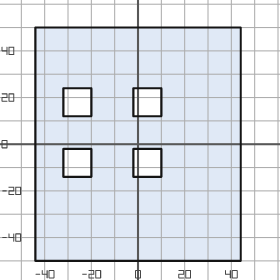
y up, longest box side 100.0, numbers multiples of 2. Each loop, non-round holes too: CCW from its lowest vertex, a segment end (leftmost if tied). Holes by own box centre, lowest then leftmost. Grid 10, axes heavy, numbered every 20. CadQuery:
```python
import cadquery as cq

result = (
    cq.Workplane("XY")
    .moveTo(-44.0, -50.0)
    .lineTo(44.0, -50.0)
    .lineTo(44.0, 50.0)
    .lineTo(-44.0, 50.0)
    .close()
    .moveTo(-32.0, -14.0)
    .lineTo(-20.0, -14.0)
    .lineTo(-20.0, -2.0)
    .lineTo(-32.0, -2.0)
    .close()
    .moveTo(-2.0, -14.0)
    .lineTo(10.0, -14.0)
    .lineTo(10.0, -2.0)
    .lineTo(-2.0, -2.0)
    .close()
    .moveTo(-32.0, 12.0)
    .lineTo(-20.0, 12.0)
    .lineTo(-20.0, 24.0)
    .lineTo(-32.0, 24.0)
    .close()
    .moveTo(-2.0, 12.0)
    .lineTo(10.0, 12.0)
    .lineTo(10.0, 24.0)
    .lineTo(-2.0, 24.0)
    .close()
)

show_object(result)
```